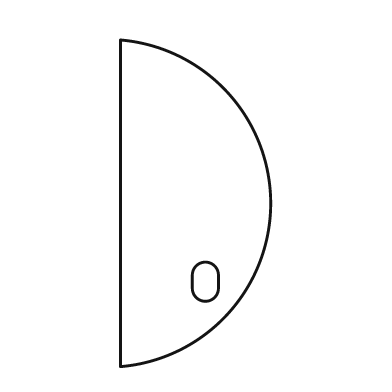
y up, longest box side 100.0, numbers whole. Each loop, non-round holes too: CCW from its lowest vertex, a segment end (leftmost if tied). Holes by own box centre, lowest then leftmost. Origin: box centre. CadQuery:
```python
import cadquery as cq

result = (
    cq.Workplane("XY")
    .moveTo(-23.0, -50.0)
    .threePointArc((23.0, 0.0), (-23.0, 50.0))
    .close()
    .moveTo(-1.0, -26.0)
    .threePointArc((3.0, -30.0), (7.0, -26.0))
    .lineTo(7.0, -22.0)
    .threePointArc((3.0, -18.0), (-1.0, -22.0))
    .close()
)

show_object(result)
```